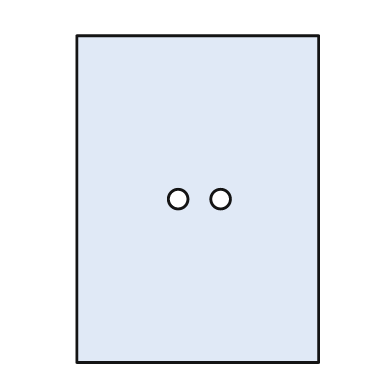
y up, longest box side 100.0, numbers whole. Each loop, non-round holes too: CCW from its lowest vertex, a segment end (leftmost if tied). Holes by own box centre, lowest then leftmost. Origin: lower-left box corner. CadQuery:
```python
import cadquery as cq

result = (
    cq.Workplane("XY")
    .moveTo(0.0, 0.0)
    .lineTo(74.0, 0.0)
    .lineTo(74.0, 100.0)
    .lineTo(0.0, 100.0)
    .close()
    .moveTo(31.0, 50.0)
    .circle(3.0)
    .moveTo(44.0, 50.0)
    .circle(3.0)
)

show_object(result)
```